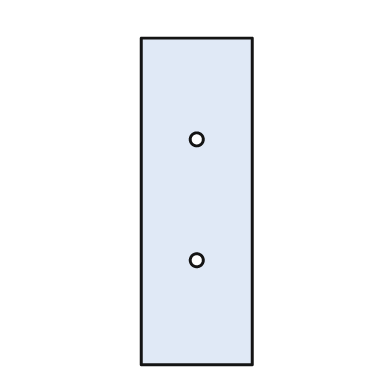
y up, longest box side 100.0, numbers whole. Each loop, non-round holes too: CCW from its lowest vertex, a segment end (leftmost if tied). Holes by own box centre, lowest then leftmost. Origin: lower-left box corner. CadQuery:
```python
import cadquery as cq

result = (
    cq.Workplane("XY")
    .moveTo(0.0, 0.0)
    .lineTo(34.0, 0.0)
    .lineTo(34.0, 100.0)
    .lineTo(0.0, 100.0)
    .close()
    .moveTo(17.0, 32.0)
    .circle(2.0)
    .moveTo(17.0, 69.0)
    .circle(2.0)
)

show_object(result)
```